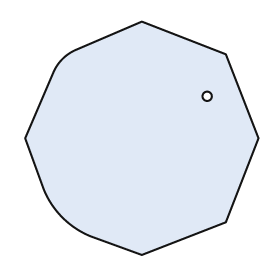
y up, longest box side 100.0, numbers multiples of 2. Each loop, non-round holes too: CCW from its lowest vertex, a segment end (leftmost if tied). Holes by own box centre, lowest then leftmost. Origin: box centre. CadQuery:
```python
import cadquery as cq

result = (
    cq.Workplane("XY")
    .moveTo(0.0, -50.0)
    .lineTo(36.0, -36.0)
    .lineTo(50.0, 0.0)
    .lineTo(36.0, 36.0)
    .lineTo(0.0, 50.0)
    .lineTo(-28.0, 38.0)
    .threePointArc((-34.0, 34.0), (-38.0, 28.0))
    .lineTo(-50.0, 0.0)
    .lineTo(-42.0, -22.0)
    .threePointArc((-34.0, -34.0), (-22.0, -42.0))
    .close()
    .moveTo(28.0, 18.0)
    .circle(2.0)
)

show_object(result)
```